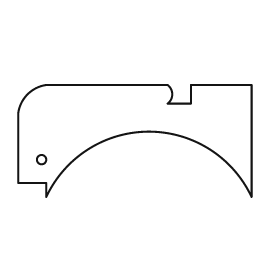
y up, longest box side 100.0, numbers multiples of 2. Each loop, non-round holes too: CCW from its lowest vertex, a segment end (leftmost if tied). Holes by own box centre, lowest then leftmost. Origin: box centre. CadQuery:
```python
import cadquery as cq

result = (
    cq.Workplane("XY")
    .moveTo(-38.0, -24.0)
    .threePointArc((6.0, 4.0), (50.0, -24.0))
    .lineTo(50.0, 24.0)
    .lineTo(24.0, 24.0)
    .lineTo(24.0, 16.0)
    .lineTo(14.0, 16.0)
    .threePointArc((16.0, 20.0), (14.0, 24.0))
    .lineTo(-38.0, 24.0)
    .threePointArc((-46.0, 20.0), (-50.0, 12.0))
    .lineTo(-50.0, -18.0)
    .lineTo(-38.0, -18.0)
    .close()
    .moveTo(-40.0, -8.0)
    .circle(2.0)
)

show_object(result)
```